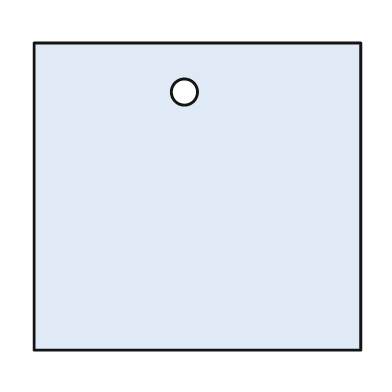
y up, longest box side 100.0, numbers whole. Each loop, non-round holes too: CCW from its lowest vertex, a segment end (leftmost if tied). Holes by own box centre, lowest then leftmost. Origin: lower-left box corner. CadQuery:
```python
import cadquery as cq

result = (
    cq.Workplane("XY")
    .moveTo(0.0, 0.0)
    .lineTo(100.0, 0.0)
    .lineTo(100.0, 94.0)
    .lineTo(0.0, 94.0)
    .close()
    .moveTo(46.0, 79.0)
    .circle(4.0)
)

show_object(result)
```